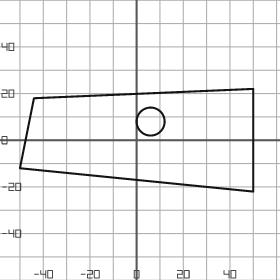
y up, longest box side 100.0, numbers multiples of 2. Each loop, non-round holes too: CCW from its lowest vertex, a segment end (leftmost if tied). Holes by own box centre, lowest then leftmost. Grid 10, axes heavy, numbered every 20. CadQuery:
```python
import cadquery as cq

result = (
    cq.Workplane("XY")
    .moveTo(50.0, -22.0)
    .lineTo(50.0, 22.0)
    .lineTo(-44.0, 18.0)
    .lineTo(-50.0, -12.0)
    .close()
    .moveTo(6.0, 8.0)
    .circle(6.0)
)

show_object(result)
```